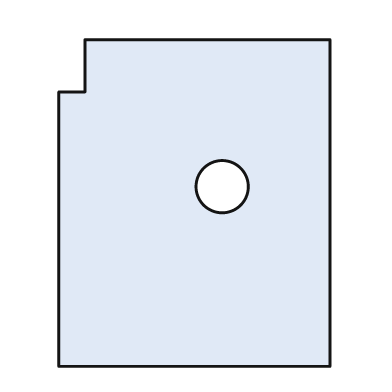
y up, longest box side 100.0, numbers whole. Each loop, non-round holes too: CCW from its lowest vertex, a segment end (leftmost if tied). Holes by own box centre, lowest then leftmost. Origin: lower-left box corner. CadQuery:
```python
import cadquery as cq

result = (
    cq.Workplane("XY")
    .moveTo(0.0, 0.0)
    .lineTo(83.0, 0.0)
    .lineTo(83.0, 100.0)
    .lineTo(8.0, 100.0)
    .lineTo(8.0, 84.0)
    .lineTo(0.0, 84.0)
    .close()
    .moveTo(50.0, 55.0)
    .circle(8.0)
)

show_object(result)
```